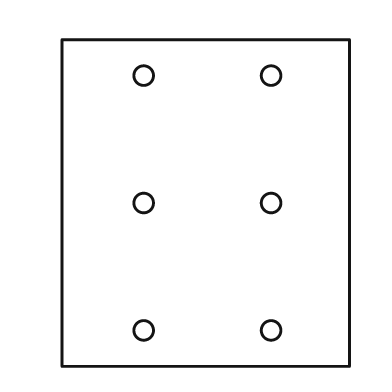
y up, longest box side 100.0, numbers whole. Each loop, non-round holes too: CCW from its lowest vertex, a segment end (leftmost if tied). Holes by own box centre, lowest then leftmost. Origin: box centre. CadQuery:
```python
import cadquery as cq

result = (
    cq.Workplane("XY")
    .moveTo(-44.0, -50.0)
    .lineTo(44.0, -50.0)
    .lineTo(44.0, 50.0)
    .lineTo(-44.0, 50.0)
    .close()
    .moveTo(-19.0, -39.0)
    .circle(3.0)
    .moveTo(20.0, -39.0)
    .circle(3.0)
    .moveTo(-19.0, 0.0)
    .circle(3.0)
    .moveTo(20.0, 0.0)
    .circle(3.0)
    .moveTo(-19.0, 39.0)
    .circle(3.0)
    .moveTo(20.0, 39.0)
    .circle(3.0)
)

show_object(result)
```